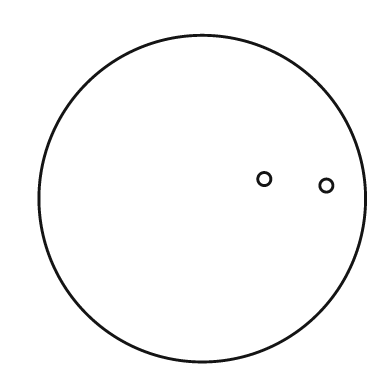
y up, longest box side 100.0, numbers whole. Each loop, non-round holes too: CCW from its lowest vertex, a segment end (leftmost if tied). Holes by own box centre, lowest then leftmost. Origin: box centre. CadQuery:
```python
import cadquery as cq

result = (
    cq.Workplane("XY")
    .moveTo(0.0, 0.0)
    .circle(50.0)
    .moveTo(38.0, 4.0)
    .circle(2.0)
    .moveTo(19.0, 6.0)
    .circle(2.0)
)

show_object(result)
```